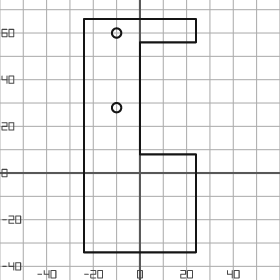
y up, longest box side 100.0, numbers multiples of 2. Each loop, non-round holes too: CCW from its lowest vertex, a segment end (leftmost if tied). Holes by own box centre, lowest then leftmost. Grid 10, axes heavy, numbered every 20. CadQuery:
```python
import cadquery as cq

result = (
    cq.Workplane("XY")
    .moveTo(-24.0, -34.0)
    .lineTo(24.0, -34.0)
    .lineTo(24.0, 8.0)
    .lineTo(0.0, 8.0)
    .lineTo(0.0, 56.0)
    .lineTo(24.0, 56.0)
    .lineTo(24.0, 66.0)
    .lineTo(-24.0, 66.0)
    .close()
    .moveTo(-10.0, 28.0)
    .circle(2.0)
    .moveTo(-10.0, 60.0)
    .circle(2.0)
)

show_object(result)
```